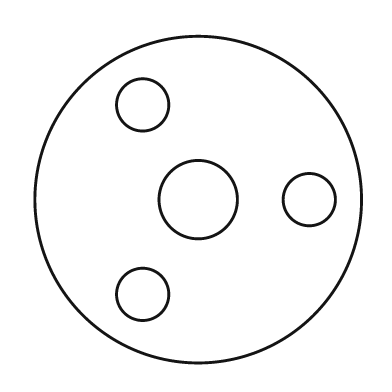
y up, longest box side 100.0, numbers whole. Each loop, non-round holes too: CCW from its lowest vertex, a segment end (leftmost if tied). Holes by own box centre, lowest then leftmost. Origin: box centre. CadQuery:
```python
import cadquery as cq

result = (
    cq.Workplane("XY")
    .moveTo(0.0, 0.0)
    .circle(50.0)
    .moveTo(-17.0, -29.0)
    .circle(8.0)
    .moveTo(0.0, 0.0)
    .circle(12.0)
    .moveTo(34.0, 0.0)
    .circle(8.0)
    .moveTo(-17.0, 29.0)
    .circle(8.0)
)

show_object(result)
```